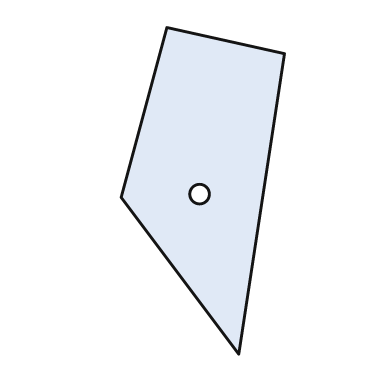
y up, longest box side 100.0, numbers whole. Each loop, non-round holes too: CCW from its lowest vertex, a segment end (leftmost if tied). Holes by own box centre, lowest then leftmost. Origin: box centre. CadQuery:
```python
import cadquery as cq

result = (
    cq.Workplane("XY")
    .moveTo(11.0, -50.0)
    .lineTo(25.0, 42.0)
    .lineTo(-11.0, 50.0)
    .lineTo(-25.0, -2.0)
    .close()
    .moveTo(-1.0, -1.0)
    .circle(3.0)
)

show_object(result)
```